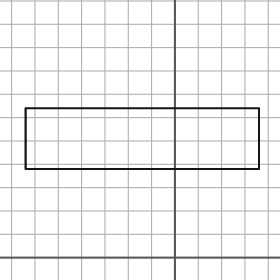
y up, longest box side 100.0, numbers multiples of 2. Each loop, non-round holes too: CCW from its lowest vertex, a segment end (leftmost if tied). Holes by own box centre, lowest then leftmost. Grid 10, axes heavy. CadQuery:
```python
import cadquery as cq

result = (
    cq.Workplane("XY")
    .moveTo(-64.0, 38.0)
    .lineTo(36.0, 38.0)
    .lineTo(36.0, 64.0)
    .lineTo(-64.0, 64.0)
    .close()
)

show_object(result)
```